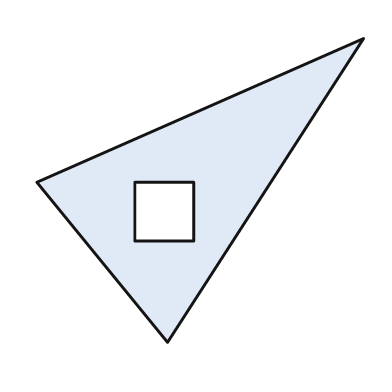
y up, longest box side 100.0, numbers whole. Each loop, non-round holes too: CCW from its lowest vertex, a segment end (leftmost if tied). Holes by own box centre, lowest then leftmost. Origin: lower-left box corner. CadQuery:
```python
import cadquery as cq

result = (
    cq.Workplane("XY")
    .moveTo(40.0, 0.0)
    .lineTo(100.0, 93.0)
    .lineTo(0.0, 49.0)
    .close()
    .moveTo(30.0, 31.0)
    .lineTo(48.0, 31.0)
    .lineTo(48.0, 49.0)
    .lineTo(30.0, 49.0)
    .close()
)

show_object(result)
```